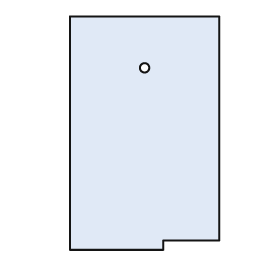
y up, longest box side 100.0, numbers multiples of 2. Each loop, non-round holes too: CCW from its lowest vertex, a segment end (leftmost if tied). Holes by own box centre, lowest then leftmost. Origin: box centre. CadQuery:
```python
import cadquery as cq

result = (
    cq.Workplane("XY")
    .moveTo(-32.0, -50.0)
    .lineTo(8.0, -50.0)
    .lineTo(8.0, -46.0)
    .lineTo(32.0, -46.0)
    .lineTo(32.0, 50.0)
    .lineTo(-32.0, 50.0)
    .close()
    .moveTo(0.0, 28.0)
    .circle(2.0)
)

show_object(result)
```